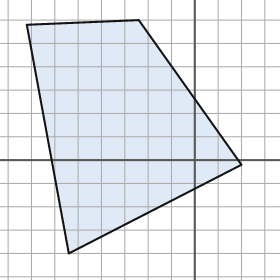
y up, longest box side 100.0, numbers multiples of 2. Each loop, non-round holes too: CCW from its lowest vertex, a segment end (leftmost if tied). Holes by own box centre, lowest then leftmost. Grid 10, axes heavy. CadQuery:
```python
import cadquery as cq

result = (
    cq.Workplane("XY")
    .moveTo(-54.0, -40.0)
    .lineTo(20.0, -2.0)
    .lineTo(-24.0, 60.0)
    .lineTo(-72.0, 58.0)
    .close()
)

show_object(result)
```